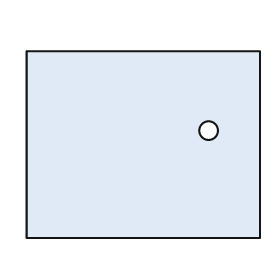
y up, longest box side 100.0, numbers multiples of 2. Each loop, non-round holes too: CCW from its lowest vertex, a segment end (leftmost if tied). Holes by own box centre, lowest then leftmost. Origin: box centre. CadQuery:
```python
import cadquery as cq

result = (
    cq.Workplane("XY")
    .moveTo(-50.0, -40.0)
    .lineTo(50.0, -40.0)
    .lineTo(50.0, 40.0)
    .lineTo(-50.0, 40.0)
    .close()
    .moveTo(28.0, 6.0)
    .circle(4.0)
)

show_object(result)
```